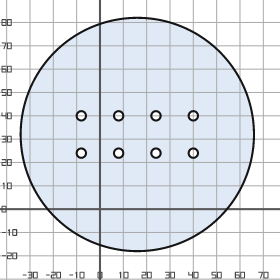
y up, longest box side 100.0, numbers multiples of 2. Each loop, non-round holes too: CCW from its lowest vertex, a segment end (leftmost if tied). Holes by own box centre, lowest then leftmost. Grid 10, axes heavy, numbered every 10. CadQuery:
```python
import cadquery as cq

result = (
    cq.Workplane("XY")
    .moveTo(16.0, 32.0)
    .circle(50.0)
    .moveTo(-8.0, 24.0)
    .circle(2.0)
    .moveTo(8.0, 24.0)
    .circle(2.0)
    .moveTo(24.0, 24.0)
    .circle(2.0)
    .moveTo(40.0, 24.0)
    .circle(2.0)
    .moveTo(-8.0, 40.0)
    .circle(2.0)
    .moveTo(8.0, 40.0)
    .circle(2.0)
    .moveTo(24.0, 40.0)
    .circle(2.0)
    .moveTo(40.0, 40.0)
    .circle(2.0)
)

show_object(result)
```